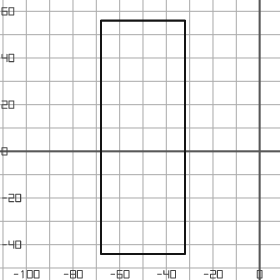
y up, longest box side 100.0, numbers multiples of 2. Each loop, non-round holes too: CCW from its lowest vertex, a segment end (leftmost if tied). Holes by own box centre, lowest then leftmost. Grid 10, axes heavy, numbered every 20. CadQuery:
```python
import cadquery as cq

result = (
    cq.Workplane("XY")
    .moveTo(-68.0, -44.0)
    .lineTo(-32.0, -44.0)
    .lineTo(-32.0, 56.0)
    .lineTo(-68.0, 56.0)
    .close()
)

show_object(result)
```